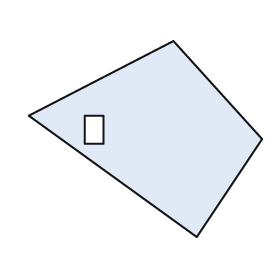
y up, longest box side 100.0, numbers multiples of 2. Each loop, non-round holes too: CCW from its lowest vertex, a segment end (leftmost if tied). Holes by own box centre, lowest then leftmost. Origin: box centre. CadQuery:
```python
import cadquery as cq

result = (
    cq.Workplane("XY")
    .moveTo(22.0, -42.0)
    .lineTo(50.0, 0.0)
    .lineTo(12.0, 42.0)
    .lineTo(-50.0, 10.0)
    .close()
    .moveTo(-26.0, -2.0)
    .lineTo(-18.0, -2.0)
    .lineTo(-18.0, 10.0)
    .lineTo(-26.0, 10.0)
    .close()
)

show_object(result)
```